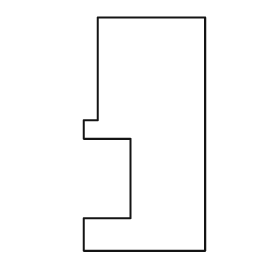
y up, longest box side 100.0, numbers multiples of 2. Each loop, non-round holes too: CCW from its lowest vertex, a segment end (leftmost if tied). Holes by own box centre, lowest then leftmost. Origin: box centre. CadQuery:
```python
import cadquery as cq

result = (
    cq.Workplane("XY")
    .moveTo(-26.0, -50.0)
    .lineTo(26.0, -50.0)
    .lineTo(26.0, 50.0)
    .lineTo(-20.0, 50.0)
    .lineTo(-20.0, 6.0)
    .lineTo(-26.0, 6.0)
    .lineTo(-26.0, -2.0)
    .lineTo(-6.0, -2.0)
    .lineTo(-6.0, -36.0)
    .lineTo(-26.0, -36.0)
    .close()
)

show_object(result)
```